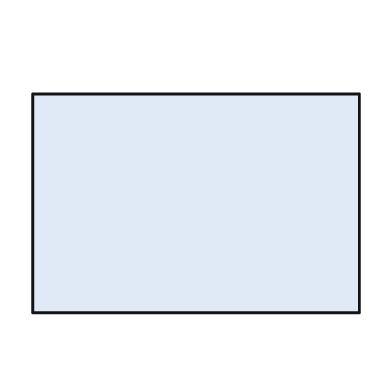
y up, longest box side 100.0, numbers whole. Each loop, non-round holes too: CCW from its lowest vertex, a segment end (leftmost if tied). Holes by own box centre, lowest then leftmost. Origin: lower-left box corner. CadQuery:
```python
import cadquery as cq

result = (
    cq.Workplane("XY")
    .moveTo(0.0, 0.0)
    .lineTo(100.0, 0.0)
    .lineTo(100.0, 67.0)
    .lineTo(0.0, 67.0)
    .close()
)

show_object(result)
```